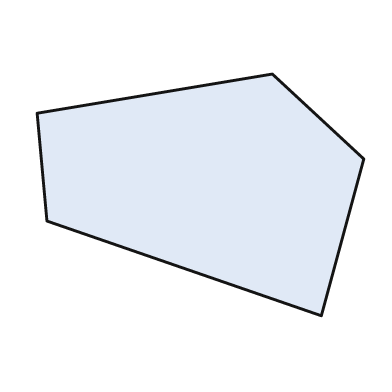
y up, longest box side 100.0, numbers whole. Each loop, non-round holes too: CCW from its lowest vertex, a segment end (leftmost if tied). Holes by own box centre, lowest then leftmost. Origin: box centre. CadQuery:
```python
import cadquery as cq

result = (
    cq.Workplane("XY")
    .moveTo(37.0, -37.0)
    .lineTo(50.0, 11.0)
    .lineTo(22.0, 37.0)
    .lineTo(-50.0, 25.0)
    .lineTo(-47.0, -8.0)
    .close()
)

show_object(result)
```